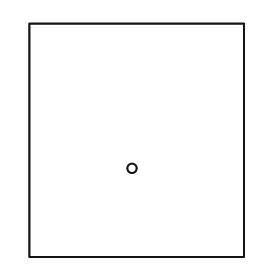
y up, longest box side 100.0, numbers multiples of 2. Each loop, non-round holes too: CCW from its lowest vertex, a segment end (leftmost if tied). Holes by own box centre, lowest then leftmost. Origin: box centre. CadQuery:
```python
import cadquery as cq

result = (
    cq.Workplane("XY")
    .moveTo(-46.0, -50.0)
    .lineTo(46.0, -50.0)
    .lineTo(46.0, 50.0)
    .lineTo(-46.0, 50.0)
    .close()
    .moveTo(-2.0, -12.0)
    .circle(2.0)
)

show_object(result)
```